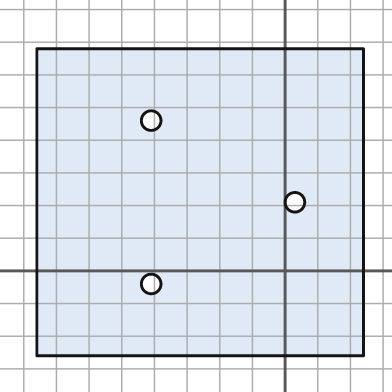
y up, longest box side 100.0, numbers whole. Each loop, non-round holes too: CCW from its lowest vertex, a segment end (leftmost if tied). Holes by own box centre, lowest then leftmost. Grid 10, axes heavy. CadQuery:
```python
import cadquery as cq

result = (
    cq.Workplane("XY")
    .moveTo(-76.0, -26.0)
    .lineTo(24.0, -26.0)
    .lineTo(24.0, 68.0)
    .lineTo(-76.0, 68.0)
    .close()
    .moveTo(-41.0, -4.0)
    .circle(3.0)
    .moveTo(3.0, 21.0)
    .circle(3.0)
    .moveTo(-41.0, 46.0)
    .circle(3.0)
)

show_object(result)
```